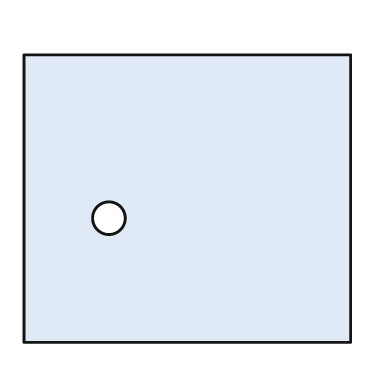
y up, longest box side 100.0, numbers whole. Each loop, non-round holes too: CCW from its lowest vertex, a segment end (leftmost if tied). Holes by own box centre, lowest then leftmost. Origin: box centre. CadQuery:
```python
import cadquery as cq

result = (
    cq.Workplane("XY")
    .moveTo(-50.0, -44.0)
    .lineTo(50.0, -44.0)
    .lineTo(50.0, 44.0)
    .lineTo(-50.0, 44.0)
    .close()
    .moveTo(-24.0, -6.0)
    .circle(5.0)
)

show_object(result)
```